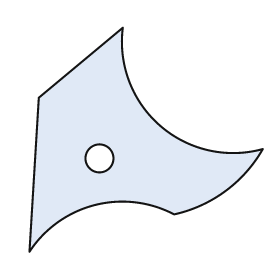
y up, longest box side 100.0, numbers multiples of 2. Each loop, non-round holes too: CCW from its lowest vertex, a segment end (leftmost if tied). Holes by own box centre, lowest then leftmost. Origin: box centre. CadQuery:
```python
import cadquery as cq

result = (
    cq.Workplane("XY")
    .moveTo(-50.0, -48.0)
    .threePointArc((-22.0, -28.0), (12.0, -32.0))
    .threePointArc((34.0, -22.0), (50.0, -4.0))
    .threePointArc((6.0, 6.0), (-10.0, 48.0))
    .lineTo(-46.0, 18.0)
    .close()
    .moveTo(-20.0, -8.0)
    .circle(6.0)
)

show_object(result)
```